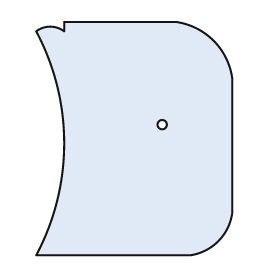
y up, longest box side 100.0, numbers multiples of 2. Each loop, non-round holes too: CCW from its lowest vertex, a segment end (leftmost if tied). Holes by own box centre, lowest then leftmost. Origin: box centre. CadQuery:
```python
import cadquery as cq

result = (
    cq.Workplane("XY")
    .moveTo(-42.0, -50.0)
    .lineTo(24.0, -50.0)
    .threePointArc((36.0, -44.0), (42.0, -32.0))
    .lineTo(42.0, 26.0)
    .threePointArc((34.0, 42.0), (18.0, 50.0))
    .lineTo(-30.0, 50.0)
    .lineTo(-30.0, 46.0)
    .threePointArc((-36.0, 48.0), (-42.0, 46.0))
    .threePointArc((-30.0, -2.0), (-42.0, -50.0))
    .close()
    .moveTo(12.0, 6.0)
    .circle(2.0)
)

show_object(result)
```